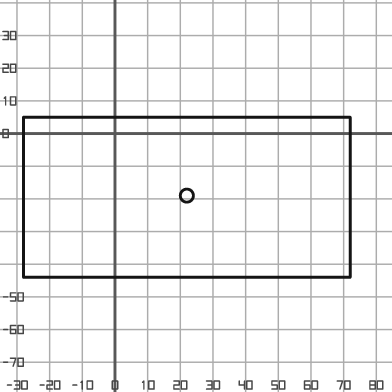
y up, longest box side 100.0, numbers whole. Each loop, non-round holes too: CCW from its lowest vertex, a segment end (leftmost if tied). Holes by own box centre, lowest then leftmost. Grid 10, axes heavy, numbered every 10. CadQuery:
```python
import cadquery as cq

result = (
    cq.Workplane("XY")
    .moveTo(-28.0, -44.0)
    .lineTo(72.0, -44.0)
    .lineTo(72.0, 5.0)
    .lineTo(-28.0, 5.0)
    .close()
    .moveTo(22.0, -19.0)
    .circle(2.0)
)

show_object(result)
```